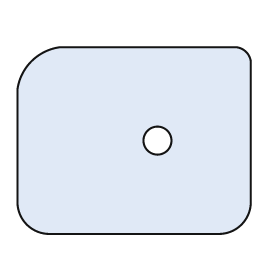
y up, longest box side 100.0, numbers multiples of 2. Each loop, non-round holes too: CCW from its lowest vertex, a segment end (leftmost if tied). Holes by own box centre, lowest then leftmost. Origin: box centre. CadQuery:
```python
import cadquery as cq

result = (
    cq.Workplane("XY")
    .moveTo(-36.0, -40.0)
    .lineTo(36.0, -40.0)
    .threePointArc((46.0, -36.0), (50.0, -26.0))
    .lineTo(50.0, 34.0)
    .threePointArc((48.0, 38.0), (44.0, 40.0))
    .lineTo(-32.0, 40.0)
    .threePointArc((-44.0, 34.0), (-50.0, 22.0))
    .lineTo(-50.0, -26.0)
    .threePointArc((-46.0, -36.0), (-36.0, -40.0))
    .close()
    .moveTo(10.0, 0.0)
    .circle(6.0)
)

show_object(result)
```